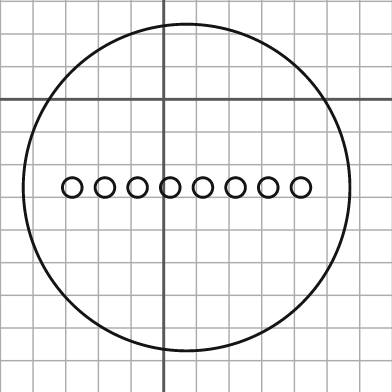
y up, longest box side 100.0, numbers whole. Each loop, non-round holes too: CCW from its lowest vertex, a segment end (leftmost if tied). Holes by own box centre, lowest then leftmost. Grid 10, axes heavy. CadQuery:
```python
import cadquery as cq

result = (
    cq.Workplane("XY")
    .moveTo(7.0, -27.0)
    .circle(50.0)
    .moveTo(-28.0, -27.0)
    .circle(3.0)
    .moveTo(-18.0, -27.0)
    .circle(3.0)
    .moveTo(-8.0, -27.0)
    .circle(3.0)
    .moveTo(2.0, -27.0)
    .circle(3.0)
    .moveTo(12.0, -27.0)
    .circle(3.0)
    .moveTo(22.0, -27.0)
    .circle(3.0)
    .moveTo(32.0, -27.0)
    .circle(3.0)
    .moveTo(42.0, -27.0)
    .circle(3.0)
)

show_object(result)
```